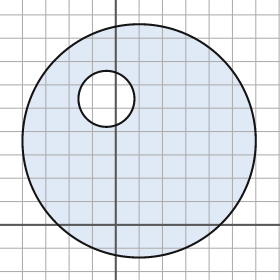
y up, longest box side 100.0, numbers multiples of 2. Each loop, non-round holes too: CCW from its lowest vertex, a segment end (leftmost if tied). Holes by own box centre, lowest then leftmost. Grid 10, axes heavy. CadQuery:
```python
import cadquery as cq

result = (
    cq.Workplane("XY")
    .moveTo(10.0, 36.0)
    .circle(50.0)
    .moveTo(-4.0, 54.0)
    .circle(12.0)
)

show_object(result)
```